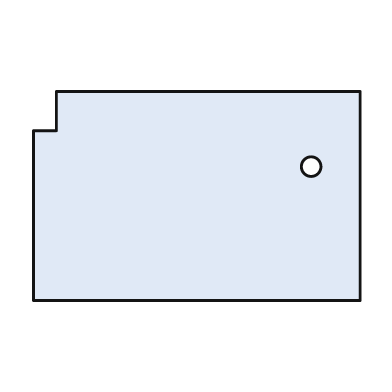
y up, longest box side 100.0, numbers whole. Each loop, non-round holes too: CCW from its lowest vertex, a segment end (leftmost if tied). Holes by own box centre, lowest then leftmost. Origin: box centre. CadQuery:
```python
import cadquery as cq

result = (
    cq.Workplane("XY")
    .moveTo(-50.0, -32.0)
    .lineTo(50.0, -32.0)
    .lineTo(50.0, 32.0)
    .lineTo(-43.0, 32.0)
    .lineTo(-43.0, 20.0)
    .lineTo(-50.0, 20.0)
    .close()
    .moveTo(35.0, 9.0)
    .circle(3.0)
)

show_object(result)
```